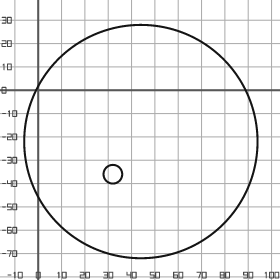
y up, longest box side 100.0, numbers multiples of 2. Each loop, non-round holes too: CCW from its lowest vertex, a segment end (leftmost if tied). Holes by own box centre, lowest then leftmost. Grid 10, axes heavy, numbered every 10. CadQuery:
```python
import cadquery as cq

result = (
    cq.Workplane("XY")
    .moveTo(44.0, -22.0)
    .circle(50.0)
    .moveTo(32.0, -36.0)
    .circle(4.0)
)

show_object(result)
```